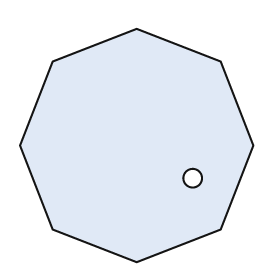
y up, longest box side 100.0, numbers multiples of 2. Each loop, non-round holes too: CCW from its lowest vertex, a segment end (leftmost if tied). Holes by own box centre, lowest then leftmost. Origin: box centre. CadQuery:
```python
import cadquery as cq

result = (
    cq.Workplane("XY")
    .moveTo(0.0, -50.0)
    .lineTo(36.0, -36.0)
    .lineTo(50.0, 0.0)
    .lineTo(36.0, 36.0)
    .lineTo(0.0, 50.0)
    .lineTo(-36.0, 36.0)
    .lineTo(-50.0, 0.0)
    .lineTo(-36.0, -36.0)
    .close()
    .moveTo(24.0, -14.0)
    .circle(4.0)
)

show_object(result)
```